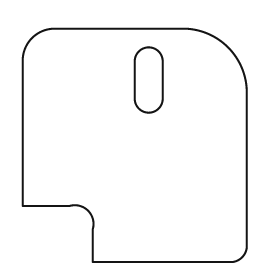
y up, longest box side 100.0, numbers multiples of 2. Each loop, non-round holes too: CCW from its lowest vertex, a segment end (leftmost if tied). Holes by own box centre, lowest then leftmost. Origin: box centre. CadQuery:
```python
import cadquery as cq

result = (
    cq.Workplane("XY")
    .moveTo(-18.0, -50.0)
    .lineTo(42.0, -50.0)
    .threePointArc((46.0, -48.0), (48.0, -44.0))
    .lineTo(48.0, 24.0)
    .threePointArc((40.0, 42.0), (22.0, 50.0))
    .lineTo(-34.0, 50.0)
    .threePointArc((-44.0, 46.0), (-48.0, 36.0))
    .lineTo(-48.0, -26.0)
    .lineTo(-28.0, -26.0)
    .threePointArc((-20.0, -28.0), (-18.0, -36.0))
    .close()
    .moveTo(0.0, 20.0)
    .threePointArc((6.0, 14.0), (12.0, 20.0))
    .lineTo(12.0, 36.0)
    .threePointArc((6.0, 42.0), (0.0, 36.0))
    .close()
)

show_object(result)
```